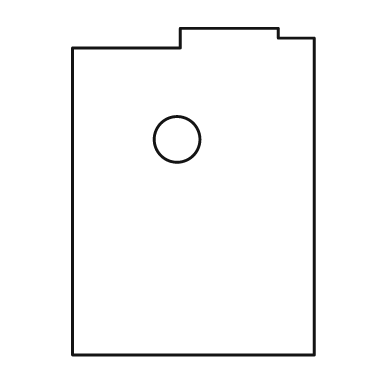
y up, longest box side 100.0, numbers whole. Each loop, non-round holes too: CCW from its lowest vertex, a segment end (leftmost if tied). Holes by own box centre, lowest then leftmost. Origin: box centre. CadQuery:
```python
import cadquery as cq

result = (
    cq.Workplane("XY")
    .moveTo(-37.0, -50.0)
    .lineTo(37.0, -50.0)
    .lineTo(37.0, 47.0)
    .lineTo(26.0, 47.0)
    .lineTo(26.0, 50.0)
    .lineTo(-4.0, 50.0)
    .lineTo(-4.0, 44.0)
    .lineTo(-37.0, 44.0)
    .close()
    .moveTo(-5.0, 16.0)
    .circle(7.0)
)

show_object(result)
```